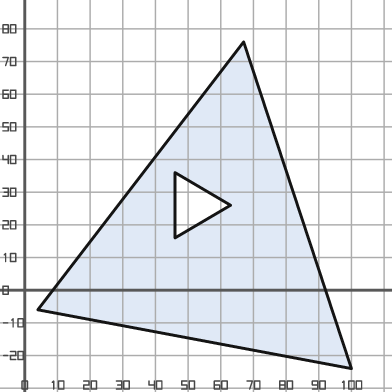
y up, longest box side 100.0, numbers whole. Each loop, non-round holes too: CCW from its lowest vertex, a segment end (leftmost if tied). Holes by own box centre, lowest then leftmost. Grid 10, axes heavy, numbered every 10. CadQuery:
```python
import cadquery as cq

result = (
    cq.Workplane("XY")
    .moveTo(100.0, -24.0)
    .lineTo(67.0, 76.0)
    .lineTo(4.0, -6.0)
    .close()
    .moveTo(46.0, 16.0)
    .lineTo(63.0, 26.0)
    .lineTo(46.0, 36.0)
    .close()
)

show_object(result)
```